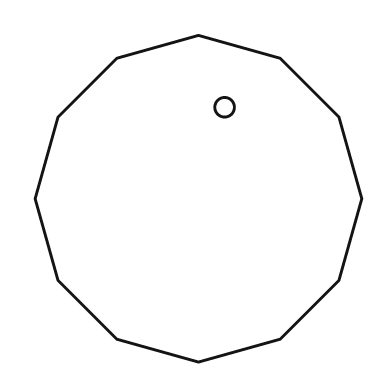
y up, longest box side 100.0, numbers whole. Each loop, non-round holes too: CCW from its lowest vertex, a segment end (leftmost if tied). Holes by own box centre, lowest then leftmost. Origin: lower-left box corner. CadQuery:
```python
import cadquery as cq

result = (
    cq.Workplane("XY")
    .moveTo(50.0, 0.0)
    .lineTo(75.0, 7.0)
    .lineTo(93.0, 25.0)
    .lineTo(100.0, 50.0)
    .lineTo(93.0, 75.0)
    .lineTo(75.0, 93.0)
    .lineTo(50.0, 100.0)
    .lineTo(25.0, 93.0)
    .lineTo(7.0, 75.0)
    .lineTo(0.0, 50.0)
    .lineTo(7.0, 25.0)
    .lineTo(25.0, 7.0)
    .close()
    .moveTo(58.0, 78.0)
    .circle(3.0)
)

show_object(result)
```